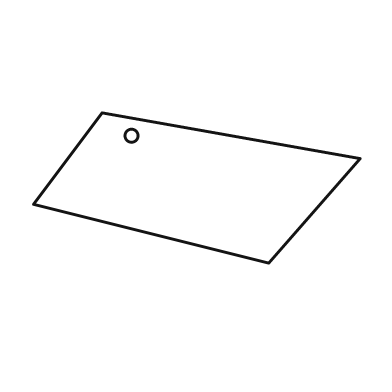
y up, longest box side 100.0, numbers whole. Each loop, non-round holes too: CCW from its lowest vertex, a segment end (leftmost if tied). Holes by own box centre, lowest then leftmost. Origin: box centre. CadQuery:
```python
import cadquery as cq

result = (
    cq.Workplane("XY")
    .moveTo(22.0, -23.0)
    .lineTo(50.0, 9.0)
    .lineTo(-29.0, 23.0)
    .lineTo(-50.0, -5.0)
    .close()
    .moveTo(-20.0, 16.0)
    .circle(2.0)
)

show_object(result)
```